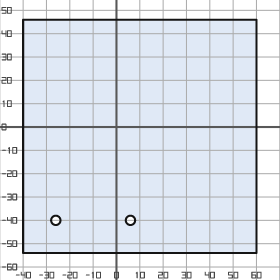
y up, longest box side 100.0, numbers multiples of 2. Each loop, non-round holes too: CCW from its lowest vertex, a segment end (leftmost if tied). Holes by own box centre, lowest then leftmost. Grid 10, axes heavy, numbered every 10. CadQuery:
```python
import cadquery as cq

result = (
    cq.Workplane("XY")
    .moveTo(-40.0, -54.0)
    .lineTo(60.0, -54.0)
    .lineTo(60.0, 46.0)
    .lineTo(-40.0, 46.0)
    .close()
    .moveTo(-26.0, -40.0)
    .circle(2.0)
    .moveTo(6.0, -40.0)
    .circle(2.0)
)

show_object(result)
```